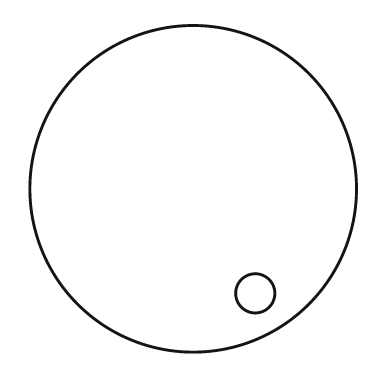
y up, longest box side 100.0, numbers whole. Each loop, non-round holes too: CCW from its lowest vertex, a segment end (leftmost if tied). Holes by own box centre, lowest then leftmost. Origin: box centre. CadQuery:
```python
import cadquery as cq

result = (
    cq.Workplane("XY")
    .moveTo(0.0, 0.0)
    .circle(50.0)
    .moveTo(19.0, -32.0)
    .circle(6.0)
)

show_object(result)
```